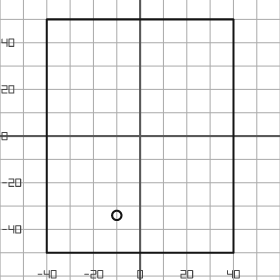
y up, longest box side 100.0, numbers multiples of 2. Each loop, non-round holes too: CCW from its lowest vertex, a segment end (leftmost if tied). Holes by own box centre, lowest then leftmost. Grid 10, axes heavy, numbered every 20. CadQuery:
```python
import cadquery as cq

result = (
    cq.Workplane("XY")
    .moveTo(-40.0, -50.0)
    .lineTo(40.0, -50.0)
    .lineTo(40.0, 50.0)
    .lineTo(-40.0, 50.0)
    .close()
    .moveTo(-10.0, -34.0)
    .circle(2.0)
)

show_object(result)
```